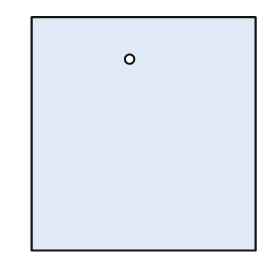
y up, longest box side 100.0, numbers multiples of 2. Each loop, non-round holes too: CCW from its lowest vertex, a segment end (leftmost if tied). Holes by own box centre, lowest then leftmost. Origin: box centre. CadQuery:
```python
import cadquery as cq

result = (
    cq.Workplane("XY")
    .moveTo(-48.0, -50.0)
    .lineTo(48.0, -50.0)
    .lineTo(48.0, 50.0)
    .lineTo(-48.0, 50.0)
    .close()
    .moveTo(-6.0, 32.0)
    .circle(2.0)
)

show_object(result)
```